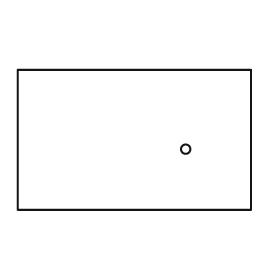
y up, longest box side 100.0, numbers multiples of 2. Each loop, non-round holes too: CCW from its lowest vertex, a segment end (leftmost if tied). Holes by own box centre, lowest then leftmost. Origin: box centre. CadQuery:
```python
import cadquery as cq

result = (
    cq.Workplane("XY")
    .moveTo(-50.0, -30.0)
    .lineTo(50.0, -30.0)
    .lineTo(50.0, 30.0)
    .lineTo(-50.0, 30.0)
    .close()
    .moveTo(22.0, -4.0)
    .circle(2.0)
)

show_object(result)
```